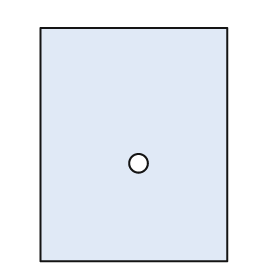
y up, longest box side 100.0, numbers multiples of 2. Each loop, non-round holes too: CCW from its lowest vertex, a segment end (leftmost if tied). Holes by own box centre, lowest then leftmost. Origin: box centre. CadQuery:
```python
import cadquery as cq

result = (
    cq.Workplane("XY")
    .moveTo(-40.0, -50.0)
    .lineTo(40.0, -50.0)
    .lineTo(40.0, 50.0)
    .lineTo(-40.0, 50.0)
    .close()
    .moveTo(2.0, -8.0)
    .circle(4.0)
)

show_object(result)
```